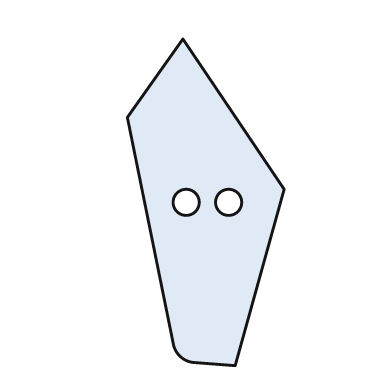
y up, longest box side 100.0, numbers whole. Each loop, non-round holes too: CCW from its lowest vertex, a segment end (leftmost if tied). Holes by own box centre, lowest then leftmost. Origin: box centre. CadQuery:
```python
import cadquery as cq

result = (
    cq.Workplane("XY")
    .moveTo(9.0, -50.0)
    .lineTo(24.0, 4.0)
    .lineTo(-7.0, 50.0)
    .lineTo(-24.0, 26.0)
    .lineTo(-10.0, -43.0)
    .threePointArc((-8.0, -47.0), (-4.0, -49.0))
    .close()
    .moveTo(-6.0, 0.0)
    .circle(4.0)
    .moveTo(7.0, 0.0)
    .circle(4.0)
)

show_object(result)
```